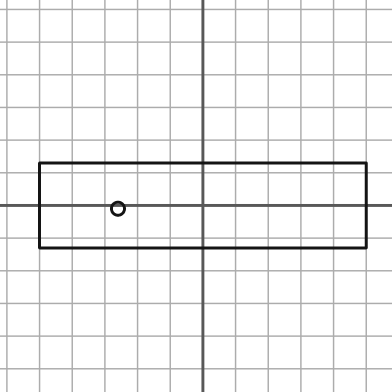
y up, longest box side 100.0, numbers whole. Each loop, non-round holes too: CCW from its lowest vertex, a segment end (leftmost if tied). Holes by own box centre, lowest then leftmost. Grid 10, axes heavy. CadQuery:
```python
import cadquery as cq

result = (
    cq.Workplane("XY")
    .moveTo(-50.0, -13.0)
    .lineTo(50.0, -13.0)
    .lineTo(50.0, 13.0)
    .lineTo(-50.0, 13.0)
    .close()
    .moveTo(-26.0, -1.0)
    .circle(2.0)
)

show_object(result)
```